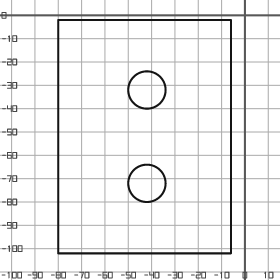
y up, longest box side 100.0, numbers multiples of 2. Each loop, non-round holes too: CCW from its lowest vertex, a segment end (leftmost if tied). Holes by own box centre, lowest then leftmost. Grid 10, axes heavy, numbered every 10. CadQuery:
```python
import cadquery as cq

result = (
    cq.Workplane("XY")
    .moveTo(-80.0, -102.0)
    .lineTo(-6.0, -102.0)
    .lineTo(-6.0, -2.0)
    .lineTo(-80.0, -2.0)
    .close()
    .moveTo(-42.0, -72.0)
    .circle(8.0)
    .moveTo(-42.0, -32.0)
    .circle(8.0)
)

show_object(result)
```